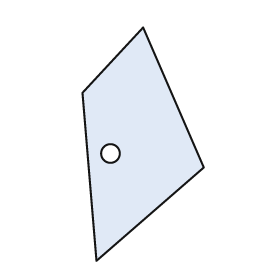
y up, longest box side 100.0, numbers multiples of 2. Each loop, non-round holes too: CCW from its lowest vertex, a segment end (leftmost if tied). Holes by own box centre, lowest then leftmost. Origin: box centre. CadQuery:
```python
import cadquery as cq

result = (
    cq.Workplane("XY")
    .moveTo(-20.0, -50.0)
    .lineTo(26.0, -10.0)
    .lineTo(0.0, 50.0)
    .lineTo(-26.0, 22.0)
    .close()
    .moveTo(-14.0, -4.0)
    .circle(4.0)
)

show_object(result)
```